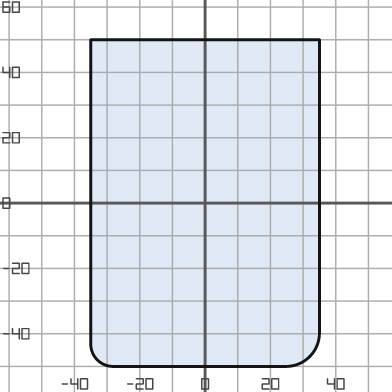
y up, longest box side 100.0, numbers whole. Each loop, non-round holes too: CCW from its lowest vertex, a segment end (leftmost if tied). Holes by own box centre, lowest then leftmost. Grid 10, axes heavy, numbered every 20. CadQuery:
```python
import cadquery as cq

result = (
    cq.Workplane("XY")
    .moveTo(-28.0, -50.0)
    .lineTo(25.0, -50.0)
    .threePointArc((32.0, -47.0), (35.0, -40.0))
    .lineTo(35.0, 50.0)
    .lineTo(-35.0, 50.0)
    .lineTo(-35.0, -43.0)
    .threePointArc((-33.0, -48.0), (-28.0, -50.0))
    .close()
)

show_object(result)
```